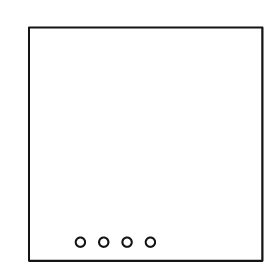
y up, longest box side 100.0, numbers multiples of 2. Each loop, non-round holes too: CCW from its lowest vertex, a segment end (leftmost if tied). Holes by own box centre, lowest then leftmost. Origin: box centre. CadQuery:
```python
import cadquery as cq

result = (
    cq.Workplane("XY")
    .moveTo(-50.0, -50.0)
    .lineTo(50.0, -50.0)
    .lineTo(50.0, 50.0)
    .lineTo(-50.0, 50.0)
    .close()
    .moveTo(-28.0, -42.0)
    .circle(2.0)
    .moveTo(-18.0, -42.0)
    .circle(2.0)
    .moveTo(-8.0, -42.0)
    .circle(2.0)
    .moveTo(2.0, -42.0)
    .circle(2.0)
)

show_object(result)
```